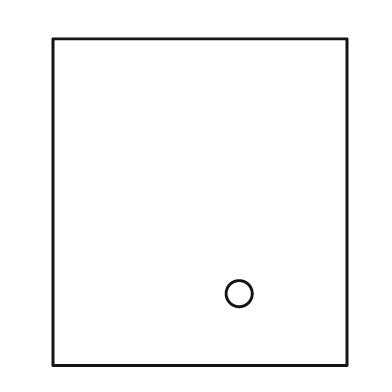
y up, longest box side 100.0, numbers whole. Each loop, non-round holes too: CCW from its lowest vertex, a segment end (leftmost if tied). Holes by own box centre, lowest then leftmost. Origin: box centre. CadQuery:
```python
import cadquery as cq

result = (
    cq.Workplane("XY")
    .moveTo(-45.0, -50.0)
    .lineTo(45.0, -50.0)
    .lineTo(45.0, 50.0)
    .lineTo(-45.0, 50.0)
    .close()
    .moveTo(12.0, -28.0)
    .circle(4.0)
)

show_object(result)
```